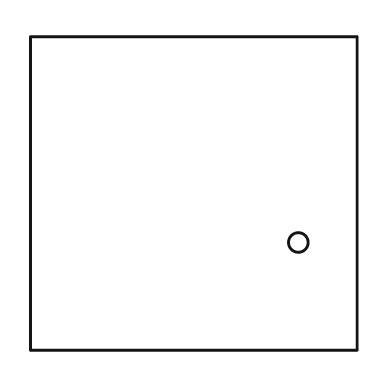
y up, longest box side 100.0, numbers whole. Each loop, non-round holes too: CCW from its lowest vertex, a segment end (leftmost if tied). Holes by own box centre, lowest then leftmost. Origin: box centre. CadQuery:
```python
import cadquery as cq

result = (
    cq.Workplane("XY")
    .moveTo(-50.0, -48.0)
    .lineTo(50.0, -48.0)
    .lineTo(50.0, 48.0)
    .lineTo(-50.0, 48.0)
    .close()
    .moveTo(32.0, -15.0)
    .circle(3.0)
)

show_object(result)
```